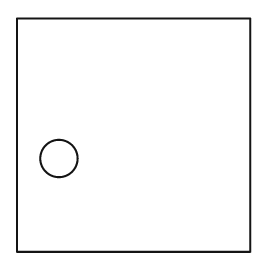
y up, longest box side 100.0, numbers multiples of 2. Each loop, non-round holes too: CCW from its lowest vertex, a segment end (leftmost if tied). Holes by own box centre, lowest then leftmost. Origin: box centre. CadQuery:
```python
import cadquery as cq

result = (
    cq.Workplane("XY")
    .moveTo(-50.0, -50.0)
    .lineTo(50.0, -50.0)
    .lineTo(50.0, 50.0)
    .lineTo(-50.0, 50.0)
    .close()
    .moveTo(-32.0, -10.0)
    .circle(8.0)
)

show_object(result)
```